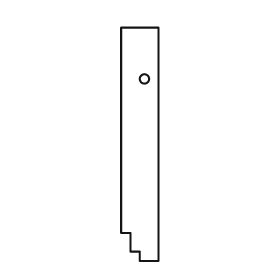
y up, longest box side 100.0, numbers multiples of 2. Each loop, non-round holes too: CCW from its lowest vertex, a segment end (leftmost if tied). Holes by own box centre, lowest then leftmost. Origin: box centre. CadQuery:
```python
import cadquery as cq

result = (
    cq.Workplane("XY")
    .moveTo(0.0, -50.0)
    .lineTo(8.0, -50.0)
    .lineTo(8.0, 50.0)
    .lineTo(-8.0, 50.0)
    .lineTo(-8.0, -38.0)
    .lineTo(-4.0, -38.0)
    .lineTo(-4.0, -46.0)
    .lineTo(0.0, -46.0)
    .close()
    .moveTo(2.0, 28.0)
    .circle(2.0)
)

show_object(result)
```